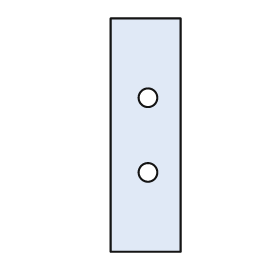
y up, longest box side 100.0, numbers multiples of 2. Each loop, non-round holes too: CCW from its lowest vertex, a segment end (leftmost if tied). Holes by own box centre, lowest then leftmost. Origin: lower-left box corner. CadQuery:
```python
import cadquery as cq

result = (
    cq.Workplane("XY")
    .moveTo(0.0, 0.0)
    .lineTo(30.0, 0.0)
    .lineTo(30.0, 100.0)
    .lineTo(0.0, 100.0)
    .close()
    .moveTo(16.0, 34.0)
    .circle(4.0)
    .moveTo(16.0, 66.0)
    .circle(4.0)
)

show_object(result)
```